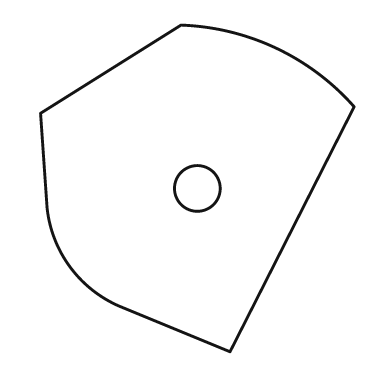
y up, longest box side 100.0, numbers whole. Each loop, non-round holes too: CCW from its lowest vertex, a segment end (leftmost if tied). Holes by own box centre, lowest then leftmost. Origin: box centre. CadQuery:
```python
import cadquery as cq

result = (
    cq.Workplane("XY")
    .moveTo(10.0, -50.0)
    .lineTo(48.0, 25.0)
    .threePointArc((24.0, 43.0), (-5.0, 50.0))
    .lineTo(-48.0, 23.0)
    .lineTo(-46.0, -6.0)
    .threePointArc((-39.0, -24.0), (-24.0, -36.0))
    .close()
    .moveTo(0.0, 0.0)
    .circle(7.0)
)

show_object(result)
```